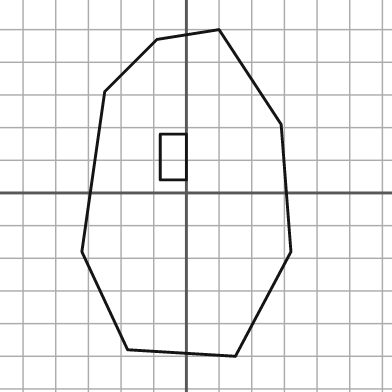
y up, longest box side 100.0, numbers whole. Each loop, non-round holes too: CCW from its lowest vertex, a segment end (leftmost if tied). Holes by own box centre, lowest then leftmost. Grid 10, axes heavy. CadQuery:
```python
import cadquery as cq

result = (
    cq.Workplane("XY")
    .moveTo(15.0, -50.0)
    .lineTo(32.0, -18.0)
    .lineTo(29.0, 21.0)
    .lineTo(10.0, 50.0)
    .lineTo(-9.0, 47.0)
    .lineTo(-25.0, 31.0)
    .lineTo(-32.0, -18.0)
    .lineTo(-18.0, -48.0)
    .close()
    .moveTo(-8.0, 4.0)
    .lineTo(0.0, 4.0)
    .lineTo(0.0, 18.0)
    .lineTo(-8.0, 18.0)
    .close()
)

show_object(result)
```